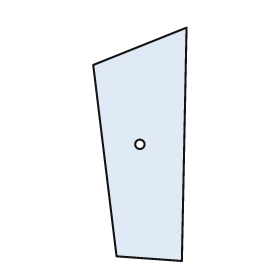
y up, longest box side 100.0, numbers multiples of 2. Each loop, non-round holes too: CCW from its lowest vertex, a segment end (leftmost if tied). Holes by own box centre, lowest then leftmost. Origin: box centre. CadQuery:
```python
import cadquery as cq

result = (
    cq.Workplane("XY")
    .moveTo(18.0, -50.0)
    .lineTo(20.0, 50.0)
    .lineTo(-20.0, 34.0)
    .lineTo(-10.0, -48.0)
    .close()
    .moveTo(0.0, 0.0)
    .circle(2.0)
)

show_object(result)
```